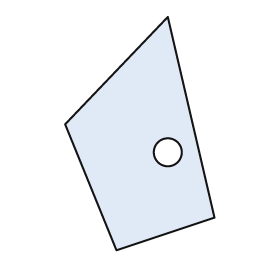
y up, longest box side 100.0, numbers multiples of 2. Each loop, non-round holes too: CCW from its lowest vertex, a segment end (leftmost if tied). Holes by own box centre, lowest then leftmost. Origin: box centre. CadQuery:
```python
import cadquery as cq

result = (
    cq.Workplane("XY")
    .moveTo(-10.0, -50.0)
    .lineTo(32.0, -36.0)
    .lineTo(12.0, 50.0)
    .lineTo(-32.0, 4.0)
    .close()
    .moveTo(12.0, -8.0)
    .circle(6.0)
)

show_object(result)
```